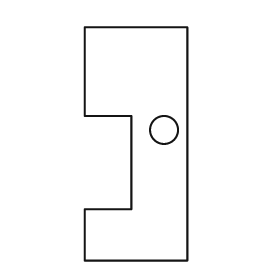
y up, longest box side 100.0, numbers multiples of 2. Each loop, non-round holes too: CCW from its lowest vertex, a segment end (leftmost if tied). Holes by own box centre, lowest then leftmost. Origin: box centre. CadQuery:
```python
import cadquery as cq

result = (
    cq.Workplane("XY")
    .moveTo(-22.0, -50.0)
    .lineTo(22.0, -50.0)
    .lineTo(22.0, 50.0)
    .lineTo(-22.0, 50.0)
    .lineTo(-22.0, 12.0)
    .lineTo(-2.0, 12.0)
    .lineTo(-2.0, -28.0)
    .lineTo(-22.0, -28.0)
    .close()
    .moveTo(12.0, 6.0)
    .circle(6.0)
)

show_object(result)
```